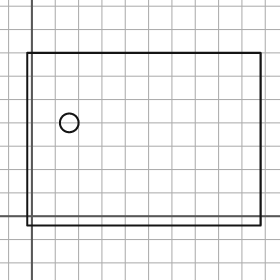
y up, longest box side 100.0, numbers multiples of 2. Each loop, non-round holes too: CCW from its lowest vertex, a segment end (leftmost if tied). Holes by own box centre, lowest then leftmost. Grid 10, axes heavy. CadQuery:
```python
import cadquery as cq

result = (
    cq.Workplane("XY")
    .moveTo(-2.0, -4.0)
    .lineTo(98.0, -4.0)
    .lineTo(98.0, 70.0)
    .lineTo(-2.0, 70.0)
    .close()
    .moveTo(16.0, 40.0)
    .circle(4.0)
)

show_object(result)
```